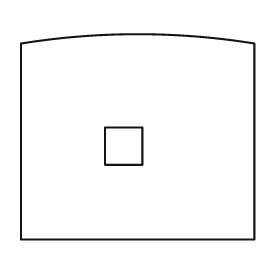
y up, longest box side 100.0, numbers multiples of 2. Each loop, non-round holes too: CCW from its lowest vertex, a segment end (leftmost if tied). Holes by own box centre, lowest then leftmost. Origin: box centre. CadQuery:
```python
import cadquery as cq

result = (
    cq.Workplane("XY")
    .moveTo(-50.0, -44.0)
    .lineTo(50.0, -44.0)
    .lineTo(50.0, 40.0)
    .threePointArc((0.0, 44.0), (-50.0, 40.0))
    .close()
    .moveTo(-14.0, -12.0)
    .lineTo(2.0, -12.0)
    .lineTo(2.0, 4.0)
    .lineTo(-14.0, 4.0)
    .close()
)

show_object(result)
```